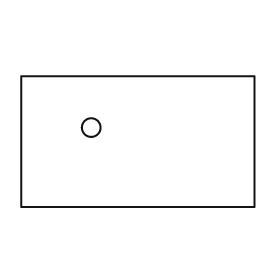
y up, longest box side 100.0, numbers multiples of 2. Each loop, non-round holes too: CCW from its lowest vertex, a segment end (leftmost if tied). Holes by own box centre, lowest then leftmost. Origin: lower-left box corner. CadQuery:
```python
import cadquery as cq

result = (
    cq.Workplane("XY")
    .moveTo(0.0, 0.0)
    .lineTo(100.0, 0.0)
    .lineTo(100.0, 56.0)
    .lineTo(0.0, 56.0)
    .close()
    .moveTo(30.0, 34.0)
    .circle(4.0)
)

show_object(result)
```